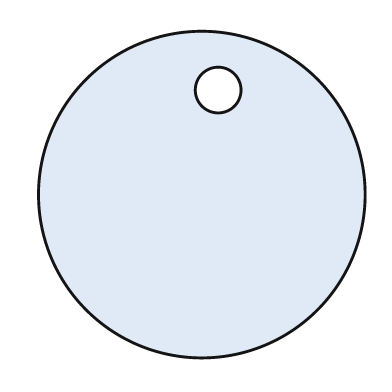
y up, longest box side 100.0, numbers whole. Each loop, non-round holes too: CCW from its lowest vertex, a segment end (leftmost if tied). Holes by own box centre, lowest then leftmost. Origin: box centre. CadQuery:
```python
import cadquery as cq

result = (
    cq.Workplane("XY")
    .moveTo(0.0, 0.0)
    .circle(50.0)
    .moveTo(5.0, 32.0)
    .circle(7.0)
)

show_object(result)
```